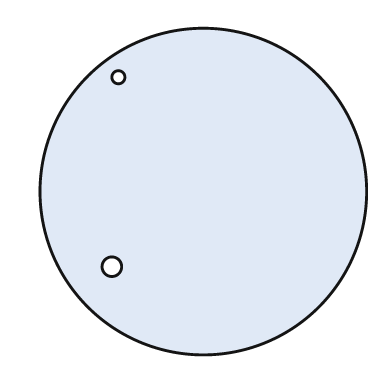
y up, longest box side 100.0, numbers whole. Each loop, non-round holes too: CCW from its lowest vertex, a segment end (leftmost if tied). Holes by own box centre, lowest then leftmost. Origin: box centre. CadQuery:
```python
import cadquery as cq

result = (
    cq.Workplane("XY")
    .moveTo(0.0, 0.0)
    .circle(50.0)
    .moveTo(-28.0, -23.0)
    .circle(3.0)
    .moveTo(-26.0, 35.0)
    .circle(2.0)
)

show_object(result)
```